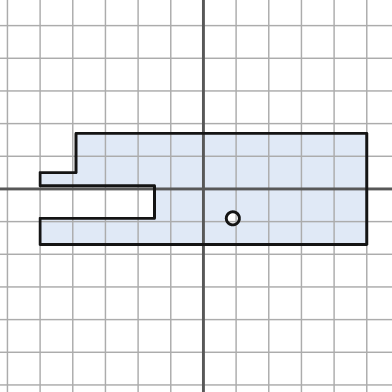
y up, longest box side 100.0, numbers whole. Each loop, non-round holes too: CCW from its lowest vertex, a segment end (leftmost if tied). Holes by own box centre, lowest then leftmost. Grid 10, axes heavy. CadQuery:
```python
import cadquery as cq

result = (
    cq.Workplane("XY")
    .moveTo(-50.0, -17.0)
    .lineTo(50.0, -17.0)
    .lineTo(50.0, 17.0)
    .lineTo(-39.0, 17.0)
    .lineTo(-39.0, 5.0)
    .lineTo(-50.0, 5.0)
    .lineTo(-50.0, 1.0)
    .lineTo(-15.0, 1.0)
    .lineTo(-15.0, -9.0)
    .lineTo(-50.0, -9.0)
    .close()
    .moveTo(9.0, -9.0)
    .circle(2.0)
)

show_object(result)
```